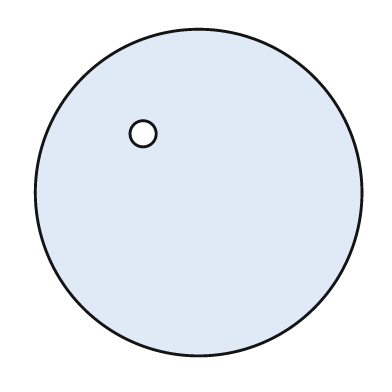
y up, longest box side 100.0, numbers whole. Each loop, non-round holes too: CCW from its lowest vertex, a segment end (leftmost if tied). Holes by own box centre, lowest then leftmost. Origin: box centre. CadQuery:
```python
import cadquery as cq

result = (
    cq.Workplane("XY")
    .moveTo(0.0, 0.0)
    .circle(50.0)
    .moveTo(-17.0, 18.0)
    .circle(4.0)
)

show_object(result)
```